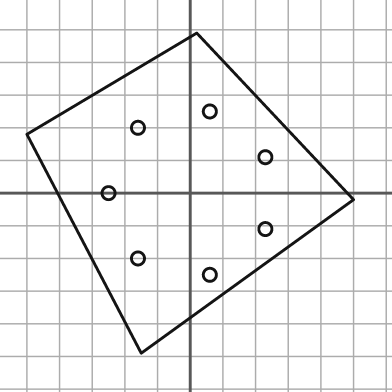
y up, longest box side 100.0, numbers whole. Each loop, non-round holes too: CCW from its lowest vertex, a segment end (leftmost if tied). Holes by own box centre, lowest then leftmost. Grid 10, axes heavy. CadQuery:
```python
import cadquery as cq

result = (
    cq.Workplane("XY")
    .moveTo(-15.0, -49.0)
    .lineTo(50.0, -2.0)
    .lineTo(2.0, 49.0)
    .lineTo(-50.0, 18.0)
    .close()
    .moveTo(6.0, -25.0)
    .circle(2.0)
    .moveTo(-16.0, -20.0)
    .circle(2.0)
    .moveTo(23.0, -11.0)
    .circle(2.0)
    .moveTo(-25.0, 0.0)
    .circle(2.0)
    .moveTo(23.0, 11.0)
    .circle(2.0)
    .moveTo(-16.0, 20.0)
    .circle(2.0)
    .moveTo(6.0, 25.0)
    .circle(2.0)
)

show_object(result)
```